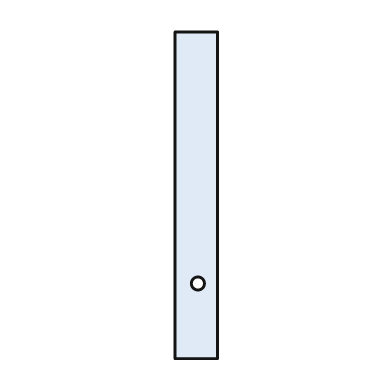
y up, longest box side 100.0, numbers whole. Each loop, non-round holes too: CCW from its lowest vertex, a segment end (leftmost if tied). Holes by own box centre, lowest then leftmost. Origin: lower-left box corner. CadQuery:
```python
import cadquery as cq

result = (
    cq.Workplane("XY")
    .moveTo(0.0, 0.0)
    .lineTo(13.0, 0.0)
    .lineTo(13.0, 100.0)
    .lineTo(0.0, 100.0)
    .close()
    .moveTo(7.0, 23.0)
    .circle(2.0)
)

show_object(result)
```